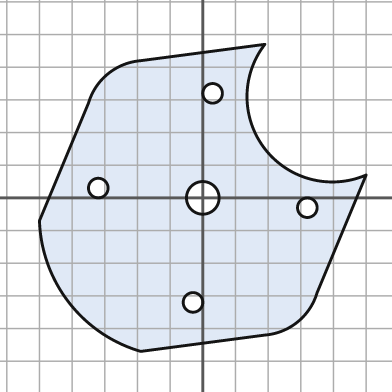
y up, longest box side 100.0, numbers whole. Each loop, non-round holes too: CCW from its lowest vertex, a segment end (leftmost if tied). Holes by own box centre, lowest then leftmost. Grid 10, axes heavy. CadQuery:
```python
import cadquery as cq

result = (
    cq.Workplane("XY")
    .moveTo(-19.0, -47.0)
    .lineTo(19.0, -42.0)
    .threePointArc((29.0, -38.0), (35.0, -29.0))
    .lineTo(50.0, 7.0)
    .threePointArc((19.0, 15.0), (19.0, 47.0))
    .lineTo(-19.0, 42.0)
    .threePointArc((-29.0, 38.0), (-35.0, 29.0))
    .lineTo(-50.0, -7.0)
    .threePointArc((-41.0, -32.0), (-19.0, -47.0))
    .close()
    .moveTo(-3.0, -32.0)
    .circle(3.0)
    .moveTo(32.0, -3.0)
    .circle(3.0)
    .moveTo(0.0, 0.0)
    .circle(5.0)
    .moveTo(-32.0, 3.0)
    .circle(3.0)
    .moveTo(3.0, 32.0)
    .circle(3.0)
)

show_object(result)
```